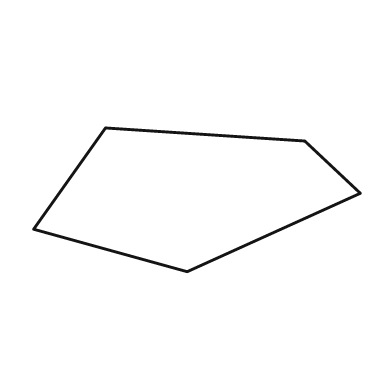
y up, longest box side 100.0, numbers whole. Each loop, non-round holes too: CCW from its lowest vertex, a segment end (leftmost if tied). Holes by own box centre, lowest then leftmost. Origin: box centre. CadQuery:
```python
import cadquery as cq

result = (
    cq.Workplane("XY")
    .moveTo(-3.0, -22.0)
    .lineTo(50.0, 2.0)
    .lineTo(33.0, 18.0)
    .lineTo(-28.0, 22.0)
    .lineTo(-50.0, -9.0)
    .close()
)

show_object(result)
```